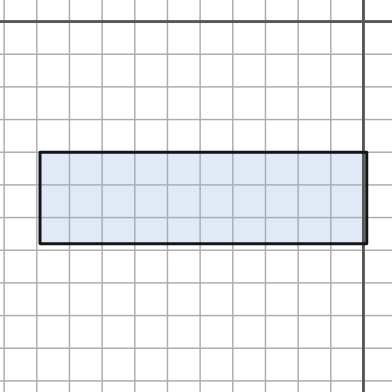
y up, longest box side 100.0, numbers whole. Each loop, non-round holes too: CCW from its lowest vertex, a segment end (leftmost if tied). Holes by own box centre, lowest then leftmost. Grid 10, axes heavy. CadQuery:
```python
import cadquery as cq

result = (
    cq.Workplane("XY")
    .moveTo(-99.0, -68.0)
    .lineTo(1.0, -68.0)
    .lineTo(1.0, -40.0)
    .lineTo(-99.0, -40.0)
    .close()
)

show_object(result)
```